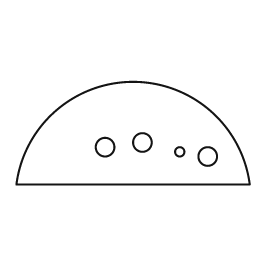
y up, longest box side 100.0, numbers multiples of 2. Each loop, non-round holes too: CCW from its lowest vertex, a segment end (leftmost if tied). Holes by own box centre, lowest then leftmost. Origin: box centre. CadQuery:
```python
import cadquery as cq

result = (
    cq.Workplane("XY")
    .moveTo(-50.0, -22.0)
    .lineTo(50.0, -22.0)
    .threePointArc((0.0, 22.0), (-50.0, -22.0))
    .close()
    .moveTo(32.0, -10.0)
    .circle(4.0)
    .moveTo(20.0, -8.0)
    .circle(2.0)
    .moveTo(-12.0, -6.0)
    .circle(4.0)
    .moveTo(4.0, -4.0)
    .circle(4.0)
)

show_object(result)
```